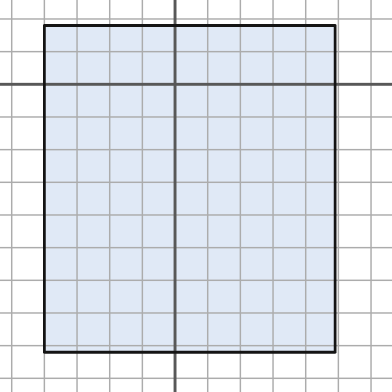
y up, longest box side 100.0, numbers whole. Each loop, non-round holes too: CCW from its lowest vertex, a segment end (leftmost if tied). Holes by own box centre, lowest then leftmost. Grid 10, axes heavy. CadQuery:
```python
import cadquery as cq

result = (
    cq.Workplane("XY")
    .moveTo(-40.0, -82.0)
    .lineTo(49.0, -82.0)
    .lineTo(49.0, 18.0)
    .lineTo(-40.0, 18.0)
    .close()
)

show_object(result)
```